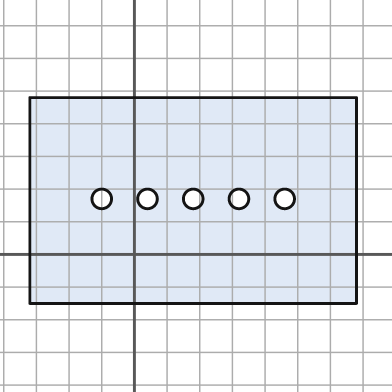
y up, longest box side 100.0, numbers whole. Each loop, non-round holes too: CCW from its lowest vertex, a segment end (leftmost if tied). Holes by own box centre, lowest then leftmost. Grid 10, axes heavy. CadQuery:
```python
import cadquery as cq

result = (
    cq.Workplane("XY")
    .moveTo(-32.0, -15.0)
    .lineTo(68.0, -15.0)
    .lineTo(68.0, 48.0)
    .lineTo(-32.0, 48.0)
    .close()
    .moveTo(-10.0, 17.0)
    .circle(3.0)
    .moveTo(4.0, 17.0)
    .circle(3.0)
    .moveTo(18.0, 17.0)
    .circle(3.0)
    .moveTo(32.0, 17.0)
    .circle(3.0)
    .moveTo(46.0, 17.0)
    .circle(3.0)
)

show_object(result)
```